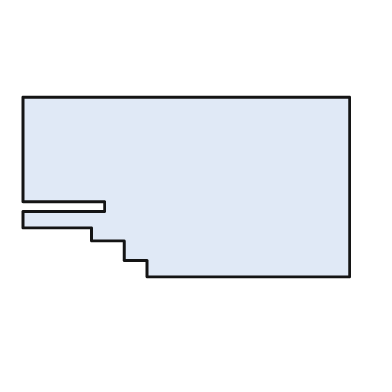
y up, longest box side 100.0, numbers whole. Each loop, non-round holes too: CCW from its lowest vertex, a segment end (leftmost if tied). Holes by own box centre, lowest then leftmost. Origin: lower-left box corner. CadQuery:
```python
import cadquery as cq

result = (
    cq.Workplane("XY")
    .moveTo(38.0, 0.0)
    .lineTo(100.0, 0.0)
    .lineTo(100.0, 55.0)
    .lineTo(0.0, 55.0)
    .lineTo(0.0, 23.0)
    .lineTo(25.0, 23.0)
    .lineTo(25.0, 20.0)
    .lineTo(0.0, 20.0)
    .lineTo(0.0, 15.0)
    .lineTo(21.0, 15.0)
    .lineTo(21.0, 11.0)
    .lineTo(31.0, 11.0)
    .lineTo(31.0, 5.0)
    .lineTo(38.0, 5.0)
    .close()
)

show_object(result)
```